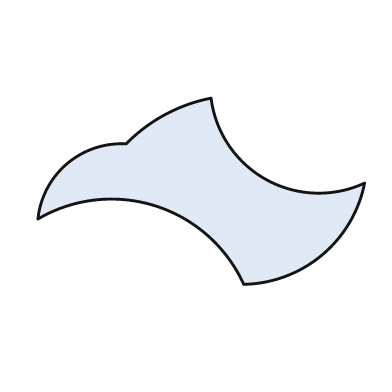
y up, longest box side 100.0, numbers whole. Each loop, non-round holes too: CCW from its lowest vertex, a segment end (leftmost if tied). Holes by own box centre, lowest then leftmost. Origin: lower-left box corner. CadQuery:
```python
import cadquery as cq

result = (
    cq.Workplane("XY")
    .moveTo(63.0, 0.0)
    .threePointArc((87.0, 9.0), (100.0, 31.0))
    .threePointArc((70.0, 32.0), (53.0, 57.0))
    .threePointArc((39.0, 52.0), (27.0, 43.0))
    .threePointArc((9.0, 37.0), (0.0, 20.0))
    .threePointArc((36.0, 24.0), (63.0, 0.0))
    .close()
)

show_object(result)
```